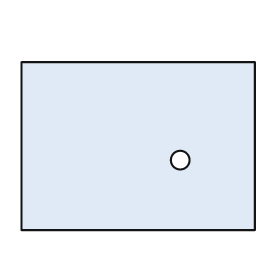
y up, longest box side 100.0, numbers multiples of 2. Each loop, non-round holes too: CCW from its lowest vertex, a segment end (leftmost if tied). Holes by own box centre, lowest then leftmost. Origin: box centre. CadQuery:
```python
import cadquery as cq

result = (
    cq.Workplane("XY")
    .moveTo(-50.0, -36.0)
    .lineTo(50.0, -36.0)
    .lineTo(50.0, 36.0)
    .lineTo(-50.0, 36.0)
    .close()
    .moveTo(18.0, -6.0)
    .circle(4.0)
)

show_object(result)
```